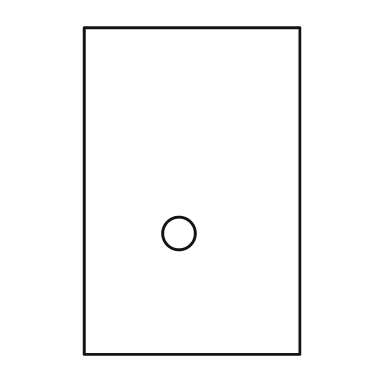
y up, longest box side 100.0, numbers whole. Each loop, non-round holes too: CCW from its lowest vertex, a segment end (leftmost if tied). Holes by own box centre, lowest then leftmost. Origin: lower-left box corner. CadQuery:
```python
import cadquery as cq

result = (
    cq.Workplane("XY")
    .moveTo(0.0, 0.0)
    .lineTo(66.0, 0.0)
    .lineTo(66.0, 100.0)
    .lineTo(0.0, 100.0)
    .close()
    .moveTo(29.0, 37.0)
    .circle(5.0)
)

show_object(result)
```